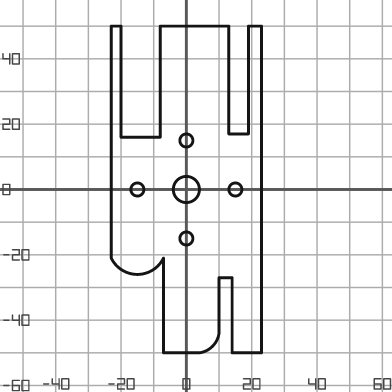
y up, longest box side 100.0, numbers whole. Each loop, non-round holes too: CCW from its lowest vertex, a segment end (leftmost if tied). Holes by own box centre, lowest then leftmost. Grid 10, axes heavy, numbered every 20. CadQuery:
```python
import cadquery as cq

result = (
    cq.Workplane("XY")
    .moveTo(-7.0, -50.0)
    .lineTo(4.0, -50.0)
    .threePointArc((8.0, -48.0), (10.0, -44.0))
    .lineTo(10.0, -27.0)
    .lineTo(14.0, -27.0)
    .lineTo(14.0, -50.0)
    .lineTo(23.0, -50.0)
    .lineTo(23.0, 50.0)
    .lineTo(19.0, 50.0)
    .lineTo(19.0, 17.0)
    .lineTo(13.0, 17.0)
    .lineTo(13.0, 50.0)
    .lineTo(-8.0, 50.0)
    .lineTo(-8.0, 16.0)
    .lineTo(-20.0, 16.0)
    .lineTo(-20.0, 50.0)
    .lineTo(-23.0, 50.0)
    .lineTo(-23.0, -21.0)
    .threePointArc((-15.0, -26.0), (-7.0, -21.0))
    .close()
    .moveTo(0.0, -15.0)
    .circle(2.0)
    .moveTo(-15.0, 0.0)
    .circle(2.0)
    .moveTo(0.0, 0.0)
    .circle(4.0)
    .moveTo(15.0, 0.0)
    .circle(2.0)
    .moveTo(0.0, 15.0)
    .circle(2.0)
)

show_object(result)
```